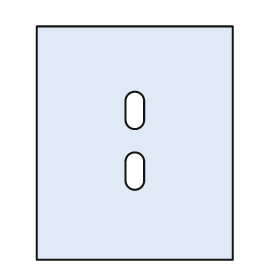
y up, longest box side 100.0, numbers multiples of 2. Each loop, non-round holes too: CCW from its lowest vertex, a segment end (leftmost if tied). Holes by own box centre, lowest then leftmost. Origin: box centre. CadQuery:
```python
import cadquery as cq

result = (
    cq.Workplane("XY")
    .moveTo(-42.0, -50.0)
    .lineTo(42.0, -50.0)
    .lineTo(42.0, 50.0)
    .lineTo(-42.0, 50.0)
    .close()
    .moveTo(-4.0, -16.0)
    .threePointArc((0.0, -20.0), (4.0, -16.0))
    .lineTo(4.0, -8.0)
    .threePointArc((0.0, -4.0), (-4.0, -8.0))
    .close()
    .moveTo(-4.0, 10.0)
    .threePointArc((0.0, 6.0), (4.0, 10.0))
    .lineTo(4.0, 18.0)
    .threePointArc((0.0, 22.0), (-4.0, 18.0))
    .close()
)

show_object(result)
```